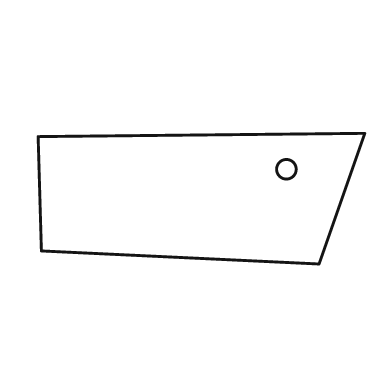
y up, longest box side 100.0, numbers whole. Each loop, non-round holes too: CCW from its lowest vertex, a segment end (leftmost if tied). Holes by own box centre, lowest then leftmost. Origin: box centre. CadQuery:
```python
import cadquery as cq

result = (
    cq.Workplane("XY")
    .moveTo(36.0, -20.0)
    .lineTo(50.0, 20.0)
    .lineTo(-50.0, 19.0)
    .lineTo(-49.0, -16.0)
    .close()
    .moveTo(26.0, 9.0)
    .circle(3.0)
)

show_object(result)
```